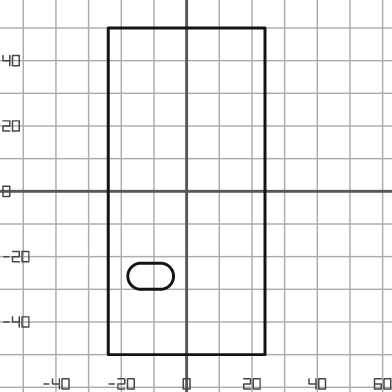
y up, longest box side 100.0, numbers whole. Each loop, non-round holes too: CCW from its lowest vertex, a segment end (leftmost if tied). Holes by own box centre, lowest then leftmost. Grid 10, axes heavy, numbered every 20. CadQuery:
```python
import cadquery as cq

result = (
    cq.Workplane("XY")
    .moveTo(-24.0, -50.0)
    .lineTo(24.0, -50.0)
    .lineTo(24.0, 50.0)
    .lineTo(-24.0, 50.0)
    .close()
    .moveTo(-14.0, -30.0)
    .lineTo(-8.0, -30.0)
    .threePointArc((-4.0, -26.0), (-8.0, -22.0))
    .lineTo(-14.0, -22.0)
    .threePointArc((-18.0, -26.0), (-14.0, -30.0))
    .close()
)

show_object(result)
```